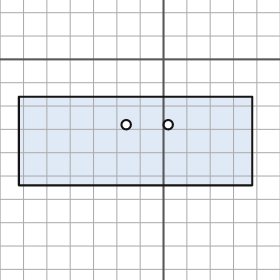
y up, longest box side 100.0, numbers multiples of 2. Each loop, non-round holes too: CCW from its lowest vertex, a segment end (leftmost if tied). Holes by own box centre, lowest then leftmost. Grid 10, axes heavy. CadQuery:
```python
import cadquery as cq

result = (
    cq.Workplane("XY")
    .moveTo(-62.0, -54.0)
    .lineTo(38.0, -54.0)
    .lineTo(38.0, -16.0)
    .lineTo(-62.0, -16.0)
    .close()
    .moveTo(-16.0, -28.0)
    .circle(2.0)
    .moveTo(2.0, -28.0)
    .circle(2.0)
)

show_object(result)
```